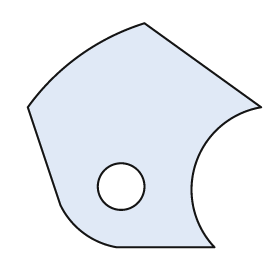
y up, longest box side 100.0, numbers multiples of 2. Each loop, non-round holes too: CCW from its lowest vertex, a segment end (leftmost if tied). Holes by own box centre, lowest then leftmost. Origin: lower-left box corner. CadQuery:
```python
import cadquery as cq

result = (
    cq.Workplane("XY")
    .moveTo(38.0, 0.0)
    .lineTo(80.0, 0.0)
    .threePointArc((72.0, 36.0), (100.0, 60.0))
    .lineTo(50.0, 96.0)
    .threePointArc((22.0, 82.0), (0.0, 60.0))
    .lineTo(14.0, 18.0)
    .threePointArc((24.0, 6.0), (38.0, 0.0))
    .close()
    .moveTo(40.0, 26.0)
    .circle(10.0)
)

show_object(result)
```